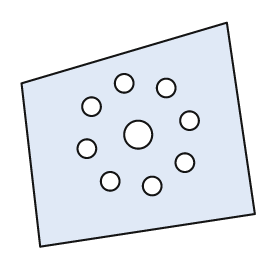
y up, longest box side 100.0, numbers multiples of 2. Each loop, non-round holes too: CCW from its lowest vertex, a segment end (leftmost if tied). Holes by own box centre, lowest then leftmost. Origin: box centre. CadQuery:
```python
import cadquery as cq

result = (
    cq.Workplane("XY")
    .moveTo(-42.0, -48.0)
    .lineTo(50.0, -34.0)
    .lineTo(38.0, 48.0)
    .lineTo(-50.0, 22.0)
    .close()
    .moveTo(6.0, -22.0)
    .circle(4.0)
    .moveTo(-12.0, -20.0)
    .circle(4.0)
    .moveTo(20.0, -12.0)
    .circle(4.0)
    .moveTo(-22.0, -6.0)
    .circle(4.0)
    .moveTo(0.0, 0.0)
    .circle(6.0)
    .moveTo(22.0, 6.0)
    .circle(4.0)
    .moveTo(-20.0, 12.0)
    .circle(4.0)
    .moveTo(12.0, 20.0)
    .circle(4.0)
    .moveTo(-6.0, 22.0)
    .circle(4.0)
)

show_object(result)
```